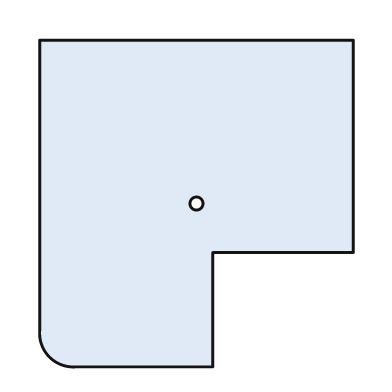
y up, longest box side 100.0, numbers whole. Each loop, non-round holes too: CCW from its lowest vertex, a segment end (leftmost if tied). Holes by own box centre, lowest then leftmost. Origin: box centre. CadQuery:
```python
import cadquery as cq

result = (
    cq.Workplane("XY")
    .moveTo(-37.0, -50.0)
    .lineTo(5.0, -50.0)
    .lineTo(5.0, -15.0)
    .lineTo(48.0, -15.0)
    .lineTo(48.0, 50.0)
    .lineTo(-48.0, 50.0)
    .lineTo(-48.0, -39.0)
    .threePointArc((-45.0, -47.0), (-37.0, -50.0))
    .close()
    .moveTo(0.0, 0.0)
    .circle(2.0)
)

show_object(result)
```